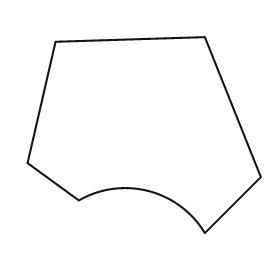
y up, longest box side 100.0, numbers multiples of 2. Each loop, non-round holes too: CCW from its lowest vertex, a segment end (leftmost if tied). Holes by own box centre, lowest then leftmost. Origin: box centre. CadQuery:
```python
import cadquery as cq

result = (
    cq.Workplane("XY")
    .moveTo(26.0, -42.0)
    .lineTo(50.0, -18.0)
    .lineTo(26.0, 42.0)
    .lineTo(-38.0, 40.0)
    .lineTo(-50.0, -12.0)
    .lineTo(-28.0, -28.0)
    .threePointArc((2.0, -24.0), (26.0, -42.0))
    .close()
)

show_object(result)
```